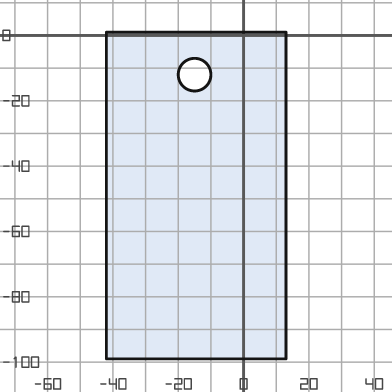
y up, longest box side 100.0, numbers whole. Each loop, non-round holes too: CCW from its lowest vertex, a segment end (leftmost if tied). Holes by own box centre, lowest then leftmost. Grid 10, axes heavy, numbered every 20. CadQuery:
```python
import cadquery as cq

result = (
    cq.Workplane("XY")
    .moveTo(-42.0, -99.0)
    .lineTo(13.0, -99.0)
    .lineTo(13.0, 1.0)
    .lineTo(-42.0, 1.0)
    .close()
    .moveTo(-15.0, -12.0)
    .circle(5.0)
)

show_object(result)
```